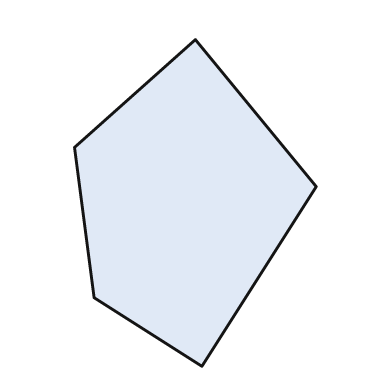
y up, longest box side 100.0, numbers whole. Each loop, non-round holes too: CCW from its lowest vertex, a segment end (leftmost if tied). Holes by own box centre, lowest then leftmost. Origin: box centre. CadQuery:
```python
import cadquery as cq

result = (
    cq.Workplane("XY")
    .moveTo(2.0, -50.0)
    .lineTo(37.0, 5.0)
    .lineTo(0.0, 50.0)
    .lineTo(-37.0, 17.0)
    .lineTo(-31.0, -29.0)
    .close()
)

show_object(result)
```